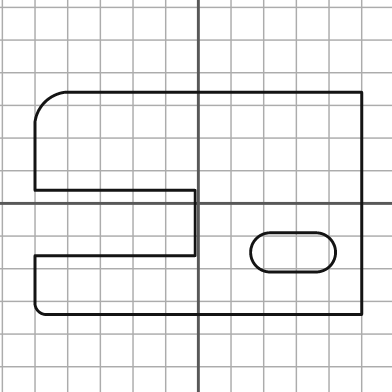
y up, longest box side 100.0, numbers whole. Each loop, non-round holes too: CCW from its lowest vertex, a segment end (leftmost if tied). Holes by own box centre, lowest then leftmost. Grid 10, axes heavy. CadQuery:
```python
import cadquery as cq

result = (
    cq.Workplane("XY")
    .moveTo(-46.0, -34.0)
    .lineTo(50.0, -34.0)
    .lineTo(50.0, 34.0)
    .lineTo(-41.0, 34.0)
    .threePointArc((-47.0, 31.0), (-50.0, 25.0))
    .lineTo(-50.0, 4.0)
    .lineTo(-1.0, 4.0)
    .lineTo(-1.0, -16.0)
    .lineTo(-50.0, -16.0)
    .lineTo(-50.0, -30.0)
    .threePointArc((-49.0, -33.0), (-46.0, -34.0))
    .close()
    .moveTo(22.0, -21.0)
    .lineTo(36.0, -21.0)
    .threePointArc((42.0, -15.0), (36.0, -9.0))
    .lineTo(22.0, -9.0)
    .threePointArc((16.0, -15.0), (22.0, -21.0))
    .close()
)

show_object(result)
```